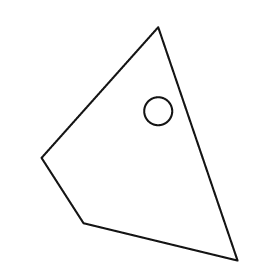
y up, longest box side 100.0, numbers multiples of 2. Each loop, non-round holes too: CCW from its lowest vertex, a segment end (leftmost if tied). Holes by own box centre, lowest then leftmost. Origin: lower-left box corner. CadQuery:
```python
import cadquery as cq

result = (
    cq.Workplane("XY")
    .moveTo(84.0, 0.0)
    .lineTo(50.0, 100.0)
    .lineTo(0.0, 44.0)
    .lineTo(18.0, 16.0)
    .close()
    .moveTo(50.0, 64.0)
    .circle(6.0)
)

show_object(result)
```